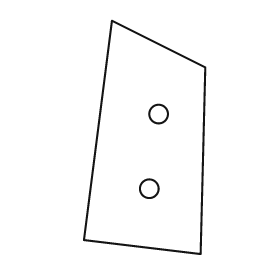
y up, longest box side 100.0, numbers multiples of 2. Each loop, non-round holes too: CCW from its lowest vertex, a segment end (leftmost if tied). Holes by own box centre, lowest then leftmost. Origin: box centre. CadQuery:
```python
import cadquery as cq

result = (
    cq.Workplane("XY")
    .moveTo(24.0, -50.0)
    .lineTo(26.0, 30.0)
    .lineTo(-14.0, 50.0)
    .lineTo(-26.0, -44.0)
    .close()
    .moveTo(2.0, -22.0)
    .circle(4.0)
    .moveTo(6.0, 10.0)
    .circle(4.0)
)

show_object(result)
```